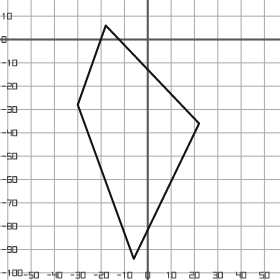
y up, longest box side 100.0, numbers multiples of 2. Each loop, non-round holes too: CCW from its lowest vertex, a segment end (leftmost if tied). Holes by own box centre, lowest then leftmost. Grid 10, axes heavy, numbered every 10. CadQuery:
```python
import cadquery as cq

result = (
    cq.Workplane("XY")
    .moveTo(-6.0, -94.0)
    .lineTo(22.0, -36.0)
    .lineTo(-18.0, 6.0)
    .lineTo(-30.0, -28.0)
    .close()
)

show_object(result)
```